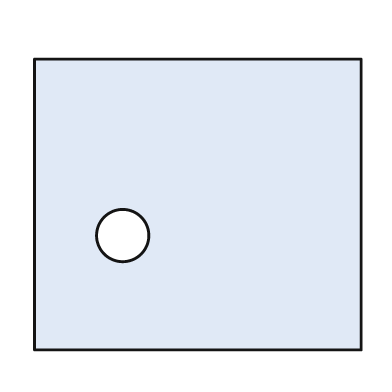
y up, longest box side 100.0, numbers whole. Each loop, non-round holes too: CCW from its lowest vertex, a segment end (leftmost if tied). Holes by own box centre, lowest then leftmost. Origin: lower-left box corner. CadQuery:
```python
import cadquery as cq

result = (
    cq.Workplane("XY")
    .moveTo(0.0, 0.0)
    .lineTo(100.0, 0.0)
    .lineTo(100.0, 89.0)
    .lineTo(0.0, 89.0)
    .close()
    .moveTo(27.0, 35.0)
    .circle(8.0)
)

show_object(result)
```